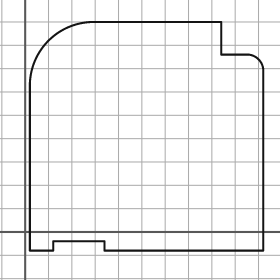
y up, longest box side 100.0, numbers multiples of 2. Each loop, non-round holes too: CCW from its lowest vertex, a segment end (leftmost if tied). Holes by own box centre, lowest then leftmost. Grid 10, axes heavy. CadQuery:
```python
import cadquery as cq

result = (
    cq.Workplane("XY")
    .moveTo(2.0, -8.0)
    .lineTo(12.0, -8.0)
    .lineTo(12.0, -4.0)
    .lineTo(34.0, -4.0)
    .lineTo(34.0, -8.0)
    .lineTo(102.0, -8.0)
    .lineTo(102.0, 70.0)
    .threePointArc((100.0, 74.0), (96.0, 76.0))
    .lineTo(84.0, 76.0)
    .lineTo(84.0, 90.0)
    .lineTo(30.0, 90.0)
    .threePointArc((10.0, 82.0), (2.0, 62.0))
    .close()
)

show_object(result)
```